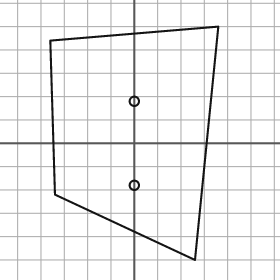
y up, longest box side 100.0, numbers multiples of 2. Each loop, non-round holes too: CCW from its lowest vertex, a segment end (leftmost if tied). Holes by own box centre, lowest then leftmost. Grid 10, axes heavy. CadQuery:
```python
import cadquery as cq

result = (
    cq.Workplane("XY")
    .moveTo(26.0, -50.0)
    .lineTo(36.0, 50.0)
    .lineTo(-36.0, 44.0)
    .lineTo(-34.0, -22.0)
    .close()
    .moveTo(0.0, -18.0)
    .circle(2.0)
    .moveTo(0.0, 18.0)
    .circle(2.0)
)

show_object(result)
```